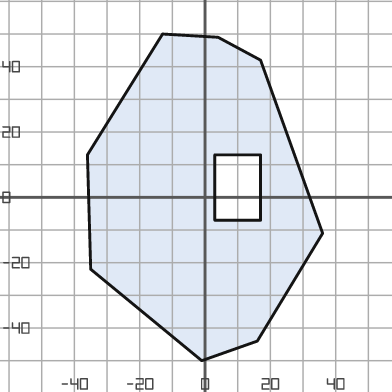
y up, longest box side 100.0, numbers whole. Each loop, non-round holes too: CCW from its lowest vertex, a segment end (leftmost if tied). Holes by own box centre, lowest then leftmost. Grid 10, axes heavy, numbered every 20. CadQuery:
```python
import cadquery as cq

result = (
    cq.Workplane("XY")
    .moveTo(-1.0, -50.0)
    .lineTo(16.0, -44.0)
    .lineTo(36.0, -11.0)
    .lineTo(17.0, 42.0)
    .lineTo(4.0, 49.0)
    .lineTo(-13.0, 50.0)
    .lineTo(-36.0, 13.0)
    .lineTo(-35.0, -22.0)
    .close()
    .moveTo(3.0, -7.0)
    .lineTo(17.0, -7.0)
    .lineTo(17.0, 13.0)
    .lineTo(3.0, 13.0)
    .close()
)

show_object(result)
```